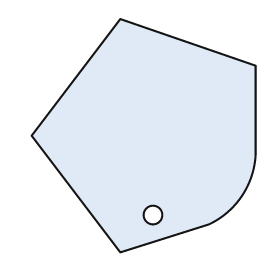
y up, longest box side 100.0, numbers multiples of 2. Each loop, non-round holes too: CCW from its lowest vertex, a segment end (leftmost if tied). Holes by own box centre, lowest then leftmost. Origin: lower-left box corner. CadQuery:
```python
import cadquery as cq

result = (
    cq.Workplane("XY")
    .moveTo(38.0, 0.0)
    .lineTo(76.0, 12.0)
    .threePointArc((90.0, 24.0), (96.0, 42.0))
    .lineTo(96.0, 80.0)
    .lineTo(38.0, 100.0)
    .lineTo(0.0, 50.0)
    .close()
    .moveTo(52.0, 16.0)
    .circle(4.0)
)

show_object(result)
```